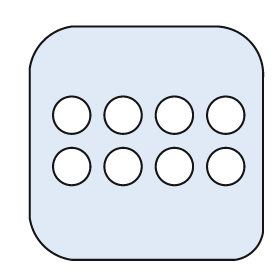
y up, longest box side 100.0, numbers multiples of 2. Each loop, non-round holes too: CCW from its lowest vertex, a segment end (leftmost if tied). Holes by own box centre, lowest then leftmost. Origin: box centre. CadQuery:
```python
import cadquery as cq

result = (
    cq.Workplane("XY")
    .moveTo(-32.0, -50.0)
    .lineTo(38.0, -50.0)
    .threePointArc((46.0, -46.0), (50.0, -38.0))
    .lineTo(50.0, 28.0)
    .threePointArc((44.0, 44.0), (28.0, 50.0))
    .lineTo(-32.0, 50.0)
    .threePointArc((-44.0, 44.0), (-50.0, 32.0))
    .lineTo(-50.0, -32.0)
    .threePointArc((-44.0, -44.0), (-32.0, -50.0))
    .close()
    .moveTo(-32.0, -10.0)
    .circle(8.0)
    .moveTo(-10.0, -10.0)
    .circle(8.0)
    .moveTo(12.0, -10.0)
    .circle(8.0)
    .moveTo(34.0, -10.0)
    .circle(8.0)
    .moveTo(-32.0, 12.0)
    .circle(8.0)
    .moveTo(-10.0, 12.0)
    .circle(8.0)
    .moveTo(12.0, 12.0)
    .circle(8.0)
    .moveTo(34.0, 12.0)
    .circle(8.0)
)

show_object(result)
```